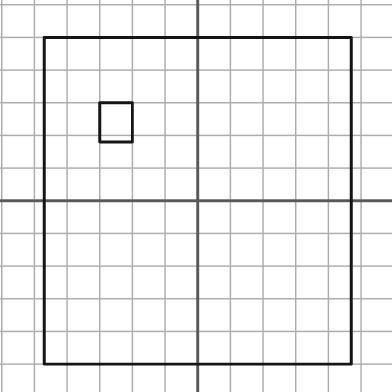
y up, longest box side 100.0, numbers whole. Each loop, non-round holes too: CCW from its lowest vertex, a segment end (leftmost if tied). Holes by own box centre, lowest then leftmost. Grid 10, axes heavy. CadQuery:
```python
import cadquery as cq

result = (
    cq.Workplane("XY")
    .moveTo(-47.0, -50.0)
    .lineTo(47.0, -50.0)
    .lineTo(47.0, 50.0)
    .lineTo(-47.0, 50.0)
    .close()
    .moveTo(-30.0, 18.0)
    .lineTo(-20.0, 18.0)
    .lineTo(-20.0, 30.0)
    .lineTo(-30.0, 30.0)
    .close()
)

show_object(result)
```